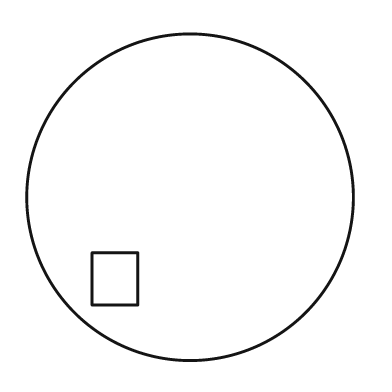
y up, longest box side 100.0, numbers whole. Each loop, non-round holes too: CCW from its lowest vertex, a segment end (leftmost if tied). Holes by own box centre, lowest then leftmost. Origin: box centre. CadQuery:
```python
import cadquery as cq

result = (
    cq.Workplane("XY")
    .moveTo(0.0, 0.0)
    .circle(50.0)
    .moveTo(-30.0, -33.0)
    .lineTo(-16.0, -33.0)
    .lineTo(-16.0, -17.0)
    .lineTo(-30.0, -17.0)
    .close()
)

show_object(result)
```